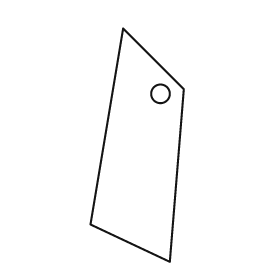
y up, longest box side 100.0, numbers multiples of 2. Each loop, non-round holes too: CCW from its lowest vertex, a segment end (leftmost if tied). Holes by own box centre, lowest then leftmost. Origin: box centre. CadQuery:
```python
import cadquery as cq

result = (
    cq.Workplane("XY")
    .moveTo(14.0, -50.0)
    .lineTo(20.0, 24.0)
    .lineTo(-6.0, 50.0)
    .lineTo(-20.0, -34.0)
    .close()
    .moveTo(10.0, 22.0)
    .circle(4.0)
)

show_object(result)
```